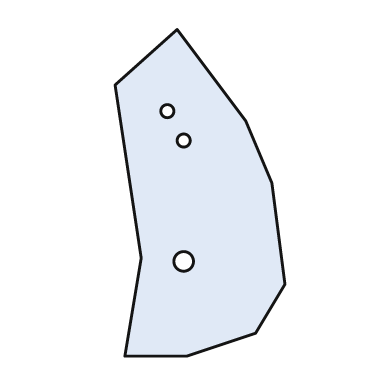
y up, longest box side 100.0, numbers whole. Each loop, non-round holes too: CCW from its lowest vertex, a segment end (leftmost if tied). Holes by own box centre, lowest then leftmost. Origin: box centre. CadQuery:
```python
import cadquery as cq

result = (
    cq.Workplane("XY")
    .moveTo(-23.0, -50.0)
    .lineTo(-4.0, -50.0)
    .lineTo(17.0, -43.0)
    .lineTo(26.0, -28.0)
    .lineTo(22.0, 3.0)
    .lineTo(14.0, 22.0)
    .lineTo(-7.0, 50.0)
    .lineTo(-26.0, 33.0)
    .lineTo(-18.0, -20.0)
    .close()
    .moveTo(-5.0, -21.0)
    .circle(3.0)
    .moveTo(-5.0, 16.0)
    .circle(2.0)
    .moveTo(-10.0, 25.0)
    .circle(2.0)
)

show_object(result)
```